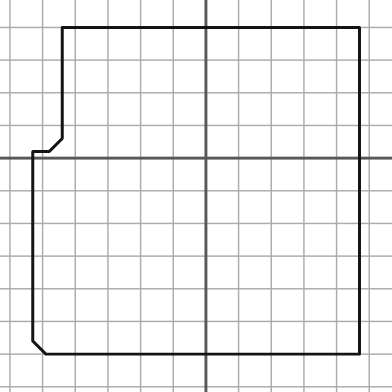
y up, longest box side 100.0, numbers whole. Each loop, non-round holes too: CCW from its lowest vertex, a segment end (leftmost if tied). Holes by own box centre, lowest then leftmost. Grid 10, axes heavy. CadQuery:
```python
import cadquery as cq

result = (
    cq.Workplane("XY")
    .moveTo(-49.0, -60.0)
    .lineTo(47.0, -60.0)
    .lineTo(47.0, 40.0)
    .lineTo(-44.0, 40.0)
    .lineTo(-44.0, 6.0)
    .lineTo(-48.0, 2.0)
    .lineTo(-53.0, 2.0)
    .lineTo(-53.0, -56.0)
    .close()
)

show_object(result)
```